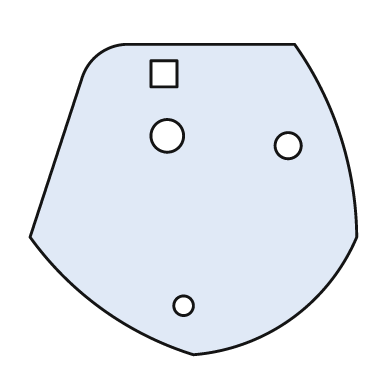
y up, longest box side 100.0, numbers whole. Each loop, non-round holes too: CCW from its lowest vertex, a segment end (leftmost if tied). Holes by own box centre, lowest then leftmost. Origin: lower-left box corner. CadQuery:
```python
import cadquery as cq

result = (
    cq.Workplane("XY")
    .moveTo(50.0, 0.0)
    .threePointArc((80.0, 11.0), (100.0, 36.0))
    .threePointArc((95.0, 67.0), (81.0, 95.0))
    .lineTo(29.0, 95.0)
    .threePointArc((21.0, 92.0), (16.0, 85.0))
    .lineTo(0.0, 36.0)
    .threePointArc((22.0, 14.0), (50.0, 0.0))
    .close()
    .moveTo(47.0, 15.0)
    .circle(3.0)
    .moveTo(79.0, 64.0)
    .circle(4.0)
    .moveTo(42.0, 67.0)
    .circle(5.0)
    .moveTo(37.0, 82.0)
    .lineTo(45.0, 82.0)
    .lineTo(45.0, 90.0)
    .lineTo(37.0, 90.0)
    .close()
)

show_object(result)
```